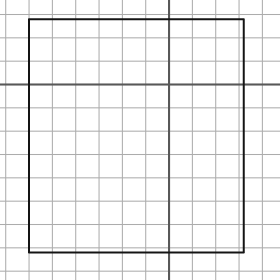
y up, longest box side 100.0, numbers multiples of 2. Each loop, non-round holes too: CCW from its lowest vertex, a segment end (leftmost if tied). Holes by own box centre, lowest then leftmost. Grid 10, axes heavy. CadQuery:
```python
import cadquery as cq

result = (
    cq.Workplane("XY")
    .moveTo(-60.0, -72.0)
    .lineTo(32.0, -72.0)
    .lineTo(32.0, 28.0)
    .lineTo(-60.0, 28.0)
    .close()
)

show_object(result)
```